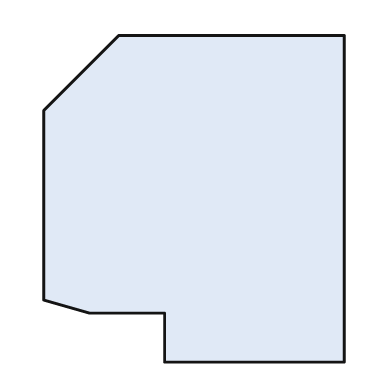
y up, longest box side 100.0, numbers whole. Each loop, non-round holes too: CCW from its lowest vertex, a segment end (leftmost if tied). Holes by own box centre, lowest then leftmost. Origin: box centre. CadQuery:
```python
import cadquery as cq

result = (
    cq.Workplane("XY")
    .moveTo(-9.0, -50.0)
    .lineTo(46.0, -50.0)
    .lineTo(46.0, 50.0)
    .lineTo(-23.0, 50.0)
    .lineTo(-46.0, 27.0)
    .lineTo(-46.0, -31.0)
    .lineTo(-32.0, -35.0)
    .lineTo(-9.0, -35.0)
    .close()
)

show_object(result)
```